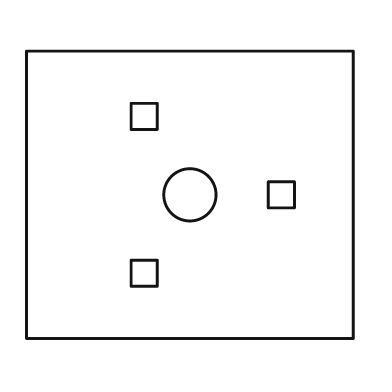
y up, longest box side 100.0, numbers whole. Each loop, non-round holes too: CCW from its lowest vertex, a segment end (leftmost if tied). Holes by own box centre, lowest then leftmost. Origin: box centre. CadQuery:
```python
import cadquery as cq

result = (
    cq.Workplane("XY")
    .moveTo(-50.0, -44.0)
    .lineTo(50.0, -44.0)
    .lineTo(50.0, 44.0)
    .lineTo(-50.0, 44.0)
    .close()
    .moveTo(-18.0, -28.0)
    .lineTo(-10.0, -28.0)
    .lineTo(-10.0, -20.0)
    .lineTo(-18.0, -20.0)
    .close()
    .moveTo(0.0, 0.0)
    .circle(8.0)
    .moveTo(24.0, -4.0)
    .lineTo(32.0, -4.0)
    .lineTo(32.0, 4.0)
    .lineTo(24.0, 4.0)
    .close()
    .moveTo(-18.0, 20.0)
    .lineTo(-10.0, 20.0)
    .lineTo(-10.0, 28.0)
    .lineTo(-18.0, 28.0)
    .close()
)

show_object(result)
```